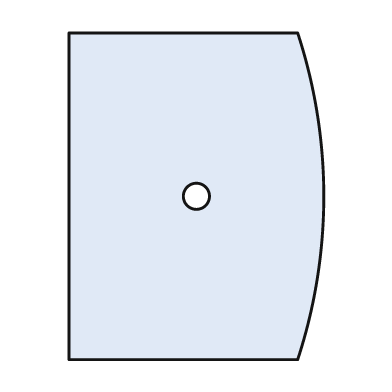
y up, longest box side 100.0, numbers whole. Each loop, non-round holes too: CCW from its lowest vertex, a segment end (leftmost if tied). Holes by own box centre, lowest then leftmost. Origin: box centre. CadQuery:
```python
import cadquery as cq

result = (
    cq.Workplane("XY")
    .moveTo(-39.0, -50.0)
    .lineTo(31.0, -50.0)
    .threePointArc((39.0, 0.0), (31.0, 50.0))
    .lineTo(-39.0, 50.0)
    .close()
    .moveTo(0.0, 0.0)
    .circle(4.0)
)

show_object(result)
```